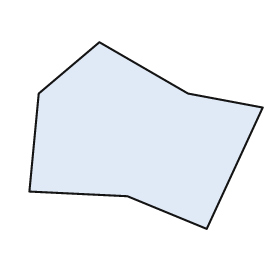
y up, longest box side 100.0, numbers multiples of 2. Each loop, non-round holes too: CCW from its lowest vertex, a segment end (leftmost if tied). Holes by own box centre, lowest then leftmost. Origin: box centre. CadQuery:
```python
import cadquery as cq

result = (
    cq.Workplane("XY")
    .moveTo(26.0, -40.0)
    .lineTo(50.0, 12.0)
    .lineTo(18.0, 18.0)
    .lineTo(-20.0, 40.0)
    .lineTo(-46.0, 18.0)
    .lineTo(-50.0, -24.0)
    .lineTo(-8.0, -26.0)
    .close()
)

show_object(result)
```